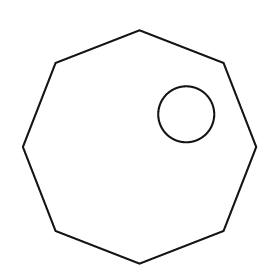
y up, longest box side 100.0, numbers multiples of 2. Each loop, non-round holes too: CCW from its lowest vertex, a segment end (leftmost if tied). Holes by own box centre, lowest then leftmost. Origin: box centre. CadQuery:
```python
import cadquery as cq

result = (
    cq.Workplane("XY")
    .moveTo(0.0, -50.0)
    .lineTo(36.0, -36.0)
    .lineTo(50.0, 0.0)
    .lineTo(36.0, 36.0)
    .lineTo(0.0, 50.0)
    .lineTo(-36.0, 36.0)
    .lineTo(-50.0, 0.0)
    .lineTo(-36.0, -36.0)
    .close()
    .moveTo(20.0, 14.0)
    .circle(12.0)
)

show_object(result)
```